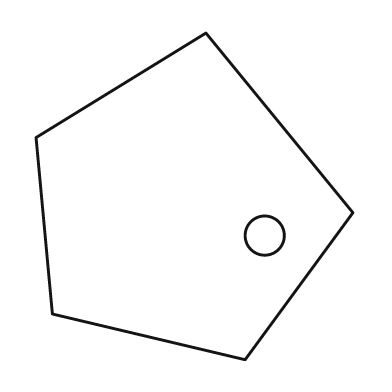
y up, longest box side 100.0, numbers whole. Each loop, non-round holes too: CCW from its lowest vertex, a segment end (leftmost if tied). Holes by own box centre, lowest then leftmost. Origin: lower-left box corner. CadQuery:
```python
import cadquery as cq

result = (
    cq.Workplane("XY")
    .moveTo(64.0, 0.0)
    .lineTo(97.0, 45.0)
    .lineTo(52.0, 100.0)
    .lineTo(0.0, 68.0)
    .lineTo(5.0, 14.0)
    .close()
    .moveTo(70.0, 38.0)
    .circle(6.0)
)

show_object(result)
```